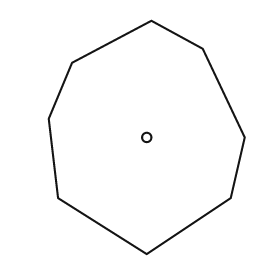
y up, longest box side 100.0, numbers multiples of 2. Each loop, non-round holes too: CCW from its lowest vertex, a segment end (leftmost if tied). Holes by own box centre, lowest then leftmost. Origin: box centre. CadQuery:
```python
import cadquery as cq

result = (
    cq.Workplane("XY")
    .moveTo(0.0, -50.0)
    .lineTo(36.0, -26.0)
    .lineTo(42.0, 0.0)
    .lineTo(24.0, 38.0)
    .lineTo(2.0, 50.0)
    .lineTo(-32.0, 32.0)
    .lineTo(-42.0, 8.0)
    .lineTo(-38.0, -26.0)
    .close()
    .moveTo(0.0, 0.0)
    .circle(2.0)
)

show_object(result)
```